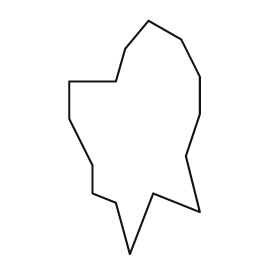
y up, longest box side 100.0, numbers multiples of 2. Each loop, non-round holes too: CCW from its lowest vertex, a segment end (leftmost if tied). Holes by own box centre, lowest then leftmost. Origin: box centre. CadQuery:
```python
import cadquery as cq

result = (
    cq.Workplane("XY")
    .moveTo(-2.0, -50.0)
    .lineTo(8.0, -24.0)
    .lineTo(28.0, -32.0)
    .lineTo(22.0, -8.0)
    .lineTo(28.0, 10.0)
    .lineTo(28.0, 26.0)
    .lineTo(20.0, 42.0)
    .lineTo(6.0, 50.0)
    .lineTo(-4.0, 38.0)
    .lineTo(-8.0, 24.0)
    .lineTo(-28.0, 24.0)
    .lineTo(-28.0, 8.0)
    .lineTo(-18.0, -12.0)
    .lineTo(-18.0, -24.0)
    .lineTo(-8.0, -28.0)
    .close()
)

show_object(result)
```